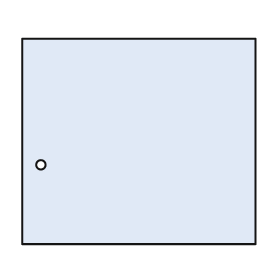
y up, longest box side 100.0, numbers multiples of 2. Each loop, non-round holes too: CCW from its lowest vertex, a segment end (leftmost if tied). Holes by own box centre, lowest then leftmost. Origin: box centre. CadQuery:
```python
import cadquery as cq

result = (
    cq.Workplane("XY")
    .moveTo(-50.0, -44.0)
    .lineTo(50.0, -44.0)
    .lineTo(50.0, 44.0)
    .lineTo(-50.0, 44.0)
    .close()
    .moveTo(-42.0, -10.0)
    .circle(2.0)
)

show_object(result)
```